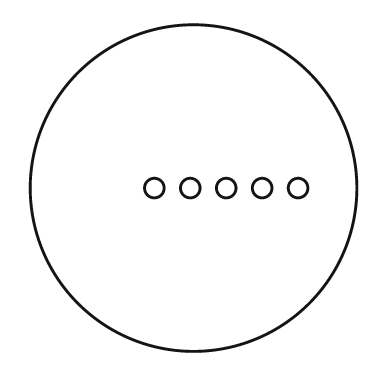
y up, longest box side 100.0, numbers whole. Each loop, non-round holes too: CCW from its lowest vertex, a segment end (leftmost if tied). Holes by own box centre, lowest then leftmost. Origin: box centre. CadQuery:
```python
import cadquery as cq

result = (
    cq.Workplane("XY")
    .moveTo(0.0, 0.0)
    .circle(50.0)
    .moveTo(-12.0, 0.0)
    .circle(3.0)
    .moveTo(-1.0, 0.0)
    .circle(3.0)
    .moveTo(10.0, 0.0)
    .circle(3.0)
    .moveTo(21.0, 0.0)
    .circle(3.0)
    .moveTo(32.0, 0.0)
    .circle(3.0)
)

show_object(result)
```